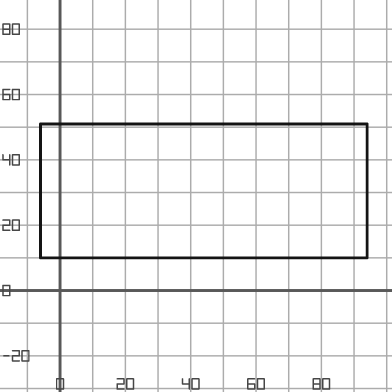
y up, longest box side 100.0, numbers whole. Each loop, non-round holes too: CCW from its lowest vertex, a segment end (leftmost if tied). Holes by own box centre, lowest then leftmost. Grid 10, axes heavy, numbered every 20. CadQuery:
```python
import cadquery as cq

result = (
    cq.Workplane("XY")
    .moveTo(-6.0, 10.0)
    .lineTo(94.0, 10.0)
    .lineTo(94.0, 51.0)
    .lineTo(-6.0, 51.0)
    .close()
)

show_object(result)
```